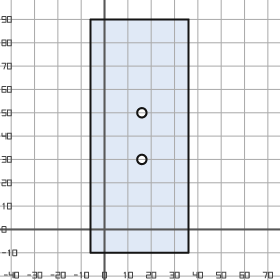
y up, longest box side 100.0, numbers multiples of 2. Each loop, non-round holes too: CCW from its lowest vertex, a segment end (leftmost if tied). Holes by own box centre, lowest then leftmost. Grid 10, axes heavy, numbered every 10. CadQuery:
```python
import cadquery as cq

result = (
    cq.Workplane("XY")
    .moveTo(-6.0, -10.0)
    .lineTo(36.0, -10.0)
    .lineTo(36.0, 90.0)
    .lineTo(-6.0, 90.0)
    .close()
    .moveTo(16.0, 30.0)
    .circle(2.0)
    .moveTo(16.0, 50.0)
    .circle(2.0)
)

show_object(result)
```